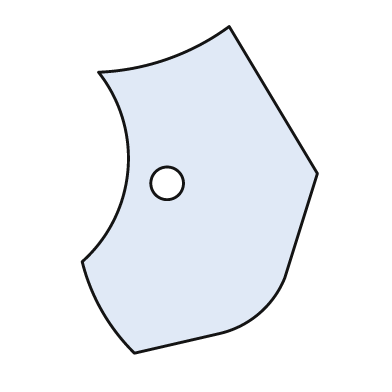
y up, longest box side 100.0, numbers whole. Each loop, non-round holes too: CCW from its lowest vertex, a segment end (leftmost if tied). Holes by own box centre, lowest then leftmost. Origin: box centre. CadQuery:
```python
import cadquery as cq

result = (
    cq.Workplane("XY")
    .moveTo(-20.0, -50.0)
    .lineTo(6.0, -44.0)
    .threePointArc((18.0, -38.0), (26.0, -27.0))
    .lineTo(36.0, 5.0)
    .lineTo(9.0, 50.0)
    .threePointArc((-10.0, 40.0), (-31.0, 36.0))
    .threePointArc((-22.0, 6.0), (-36.0, -22.0))
    .threePointArc((-30.0, -37.0), (-20.0, -50.0))
    .close()
    .moveTo(-10.0, 2.0)
    .circle(5.0)
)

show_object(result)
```